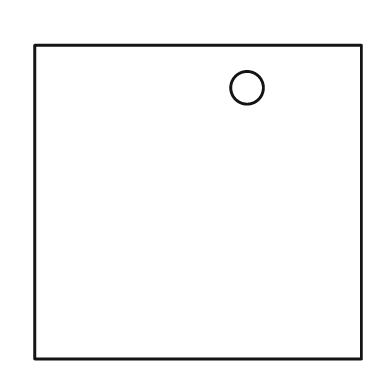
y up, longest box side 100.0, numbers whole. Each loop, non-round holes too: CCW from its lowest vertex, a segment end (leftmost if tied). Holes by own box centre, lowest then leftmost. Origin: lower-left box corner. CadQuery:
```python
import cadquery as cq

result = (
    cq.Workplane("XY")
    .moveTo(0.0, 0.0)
    .lineTo(100.0, 0.0)
    .lineTo(100.0, 96.0)
    .lineTo(0.0, 96.0)
    .close()
    .moveTo(65.0, 83.0)
    .circle(5.0)
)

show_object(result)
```